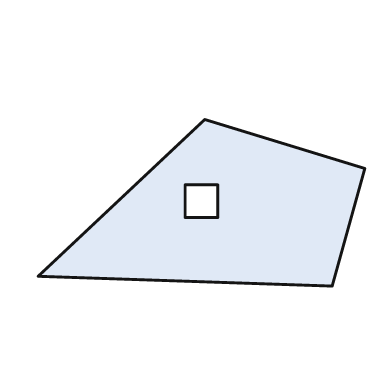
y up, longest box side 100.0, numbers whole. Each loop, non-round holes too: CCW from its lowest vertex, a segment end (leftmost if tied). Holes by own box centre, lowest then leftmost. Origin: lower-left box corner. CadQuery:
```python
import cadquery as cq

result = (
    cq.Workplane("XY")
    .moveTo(90.0, 0.0)
    .lineTo(100.0, 36.0)
    .lineTo(51.0, 51.0)
    .lineTo(0.0, 3.0)
    .close()
    .moveTo(45.0, 21.0)
    .lineTo(55.0, 21.0)
    .lineTo(55.0, 31.0)
    .lineTo(45.0, 31.0)
    .close()
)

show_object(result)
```